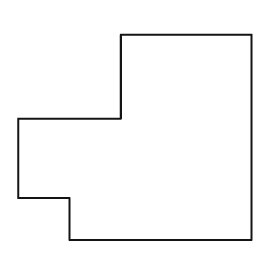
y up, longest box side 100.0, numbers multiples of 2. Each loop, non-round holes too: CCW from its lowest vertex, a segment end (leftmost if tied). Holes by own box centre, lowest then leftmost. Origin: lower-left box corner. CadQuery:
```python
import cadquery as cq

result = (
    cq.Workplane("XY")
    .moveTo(22.0, 0.0)
    .lineTo(100.0, 0.0)
    .lineTo(100.0, 88.0)
    .lineTo(44.0, 88.0)
    .lineTo(44.0, 52.0)
    .lineTo(0.0, 52.0)
    .lineTo(0.0, 18.0)
    .lineTo(22.0, 18.0)
    .close()
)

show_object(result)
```